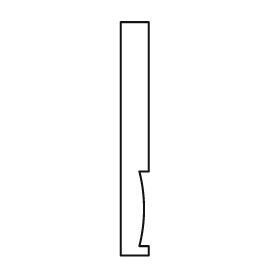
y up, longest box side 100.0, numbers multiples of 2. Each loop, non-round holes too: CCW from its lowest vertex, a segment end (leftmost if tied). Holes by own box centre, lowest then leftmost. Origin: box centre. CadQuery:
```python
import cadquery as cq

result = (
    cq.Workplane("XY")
    .moveTo(-6.0, -50.0)
    .lineTo(6.0, -50.0)
    .lineTo(6.0, -46.0)
    .lineTo(2.0, -46.0)
    .threePointArc((4.0, -30.0), (2.0, -14.0))
    .lineTo(6.0, -14.0)
    .lineTo(6.0, 50.0)
    .lineTo(-6.0, 50.0)
    .close()
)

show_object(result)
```